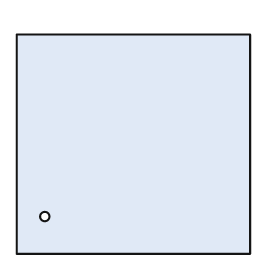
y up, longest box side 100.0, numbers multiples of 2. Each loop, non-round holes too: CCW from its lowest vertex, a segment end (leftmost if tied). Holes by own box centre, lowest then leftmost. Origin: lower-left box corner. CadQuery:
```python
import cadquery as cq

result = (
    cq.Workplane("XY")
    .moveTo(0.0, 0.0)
    .lineTo(100.0, 0.0)
    .lineTo(100.0, 94.0)
    .lineTo(0.0, 94.0)
    .close()
    .moveTo(12.0, 16.0)
    .circle(2.0)
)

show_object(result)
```